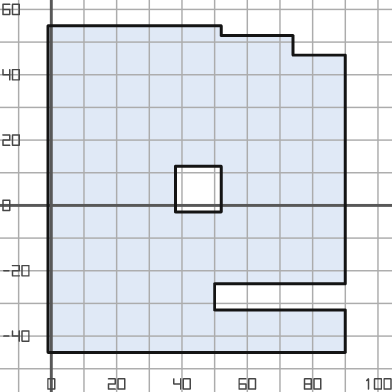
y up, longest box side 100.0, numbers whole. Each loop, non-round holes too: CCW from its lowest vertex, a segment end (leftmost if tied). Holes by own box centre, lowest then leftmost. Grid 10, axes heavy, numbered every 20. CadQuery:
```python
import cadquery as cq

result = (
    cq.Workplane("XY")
    .moveTo(-1.0, -45.0)
    .lineTo(90.0, -45.0)
    .lineTo(90.0, -32.0)
    .lineTo(50.0, -32.0)
    .lineTo(50.0, -24.0)
    .lineTo(90.0, -24.0)
    .lineTo(90.0, 46.0)
    .lineTo(74.0, 46.0)
    .lineTo(74.0, 52.0)
    .lineTo(52.0, 52.0)
    .lineTo(52.0, 55.0)
    .lineTo(-1.0, 55.0)
    .close()
    .moveTo(38.0, -2.0)
    .lineTo(52.0, -2.0)
    .lineTo(52.0, 12.0)
    .lineTo(38.0, 12.0)
    .close()
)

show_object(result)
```